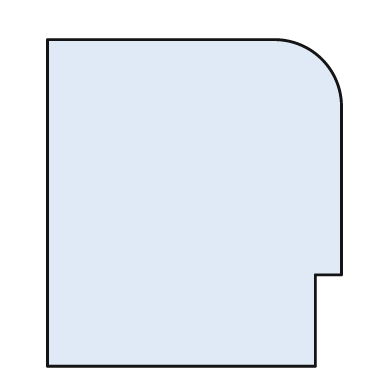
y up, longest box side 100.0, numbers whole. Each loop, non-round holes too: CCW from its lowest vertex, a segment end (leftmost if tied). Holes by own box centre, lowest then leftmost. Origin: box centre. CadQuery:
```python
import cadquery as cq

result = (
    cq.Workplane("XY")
    .moveTo(-45.0, -50.0)
    .lineTo(37.0, -50.0)
    .lineTo(37.0, -22.0)
    .lineTo(45.0, -22.0)
    .lineTo(45.0, 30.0)
    .threePointArc((39.0, 44.0), (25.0, 50.0))
    .lineTo(-45.0, 50.0)
    .close()
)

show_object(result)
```